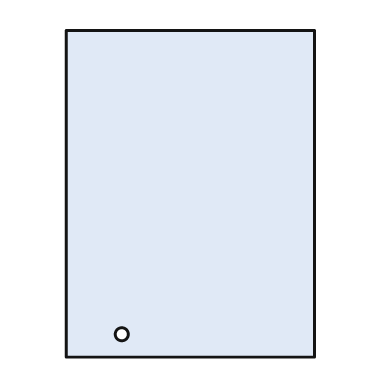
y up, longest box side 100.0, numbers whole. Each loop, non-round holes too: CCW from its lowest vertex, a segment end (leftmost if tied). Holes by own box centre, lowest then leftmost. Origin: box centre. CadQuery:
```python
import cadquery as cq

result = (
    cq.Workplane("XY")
    .moveTo(-38.0, -50.0)
    .lineTo(38.0, -50.0)
    .lineTo(38.0, 50.0)
    .lineTo(-38.0, 50.0)
    .close()
    .moveTo(-21.0, -43.0)
    .circle(2.0)
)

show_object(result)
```